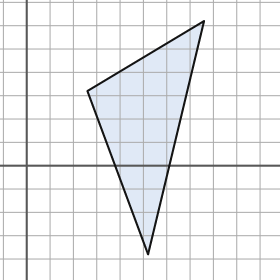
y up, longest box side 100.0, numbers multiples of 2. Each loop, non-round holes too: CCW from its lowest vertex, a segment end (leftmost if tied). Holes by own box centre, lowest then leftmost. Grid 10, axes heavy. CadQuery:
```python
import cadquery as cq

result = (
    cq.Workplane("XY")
    .moveTo(52.0, -38.0)
    .lineTo(76.0, 62.0)
    .lineTo(26.0, 32.0)
    .close()
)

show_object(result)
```